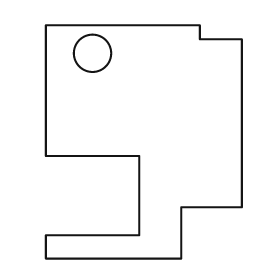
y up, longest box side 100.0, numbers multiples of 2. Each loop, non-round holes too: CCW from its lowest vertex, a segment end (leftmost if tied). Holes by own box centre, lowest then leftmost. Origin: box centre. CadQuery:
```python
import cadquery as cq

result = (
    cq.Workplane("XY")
    .moveTo(-42.0, -50.0)
    .lineTo(16.0, -50.0)
    .lineTo(16.0, -28.0)
    .lineTo(42.0, -28.0)
    .lineTo(42.0, 44.0)
    .lineTo(24.0, 44.0)
    .lineTo(24.0, 50.0)
    .lineTo(-42.0, 50.0)
    .lineTo(-42.0, -6.0)
    .lineTo(-2.0, -6.0)
    .lineTo(-2.0, -40.0)
    .lineTo(-42.0, -40.0)
    .close()
    .moveTo(-22.0, 38.0)
    .circle(8.0)
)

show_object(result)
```